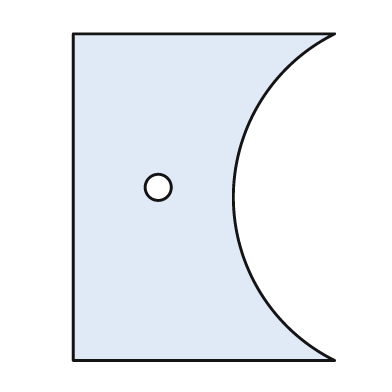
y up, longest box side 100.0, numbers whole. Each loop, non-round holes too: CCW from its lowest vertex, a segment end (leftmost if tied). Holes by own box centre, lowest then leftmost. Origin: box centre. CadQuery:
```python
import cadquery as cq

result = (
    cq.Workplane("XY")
    .moveTo(-40.0, -50.0)
    .lineTo(40.0, -50.0)
    .threePointArc((9.0, 0.0), (40.0, 50.0))
    .lineTo(-40.0, 50.0)
    .close()
    .moveTo(-14.0, 3.0)
    .circle(4.0)
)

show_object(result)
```